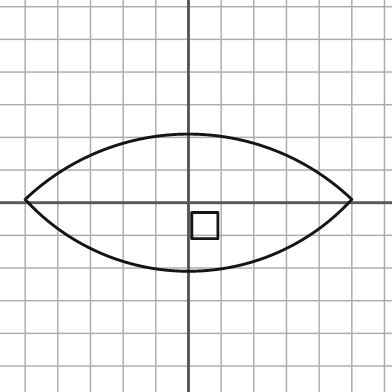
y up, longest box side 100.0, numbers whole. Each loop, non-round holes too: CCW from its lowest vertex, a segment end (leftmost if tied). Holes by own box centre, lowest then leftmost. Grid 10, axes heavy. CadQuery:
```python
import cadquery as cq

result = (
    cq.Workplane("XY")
    .moveTo(-50.0, 1.0)
    .threePointArc((0.0, -21.0), (50.0, 1.0))
    .threePointArc((0.0, 21.0), (-50.0, 1.0))
    .close()
    .moveTo(1.0, -11.0)
    .lineTo(9.0, -11.0)
    .lineTo(9.0, -3.0)
    .lineTo(1.0, -3.0)
    .close()
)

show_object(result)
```